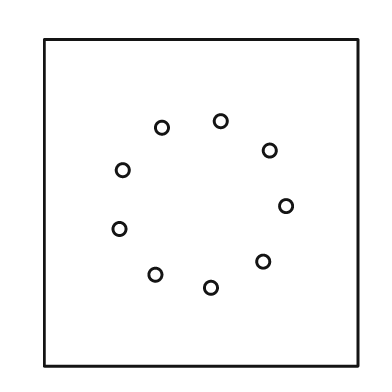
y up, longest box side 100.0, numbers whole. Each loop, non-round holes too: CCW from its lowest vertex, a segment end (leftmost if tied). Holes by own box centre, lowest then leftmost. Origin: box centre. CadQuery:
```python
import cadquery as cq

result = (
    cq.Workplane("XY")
    .moveTo(-48.0, -50.0)
    .lineTo(48.0, -50.0)
    .lineTo(48.0, 50.0)
    .lineTo(-48.0, 50.0)
    .close()
    .moveTo(3.0, -26.0)
    .circle(2.0)
    .moveTo(-14.0, -22.0)
    .circle(2.0)
    .moveTo(19.0, -18.0)
    .circle(2.0)
    .moveTo(-25.0, -8.0)
    .circle(2.0)
    .moveTo(26.0, -1.0)
    .circle(2.0)
    .moveTo(-24.0, 10.0)
    .circle(2.0)
    .moveTo(21.0, 16.0)
    .circle(2.0)
    .moveTo(-12.0, 23.0)
    .circle(2.0)
    .moveTo(6.0, 25.0)
    .circle(2.0)
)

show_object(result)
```